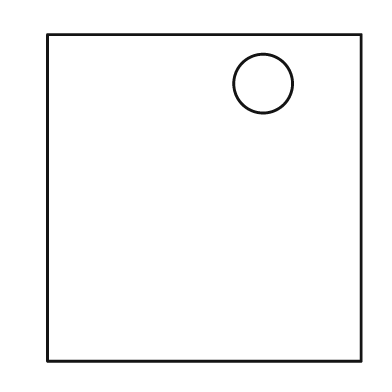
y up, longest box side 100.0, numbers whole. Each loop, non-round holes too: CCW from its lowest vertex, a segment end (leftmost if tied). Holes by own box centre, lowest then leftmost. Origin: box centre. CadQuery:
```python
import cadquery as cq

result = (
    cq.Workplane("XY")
    .moveTo(-48.0, -50.0)
    .lineTo(48.0, -50.0)
    .lineTo(48.0, 50.0)
    .lineTo(-48.0, 50.0)
    .close()
    .moveTo(18.0, 35.0)
    .circle(9.0)
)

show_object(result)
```